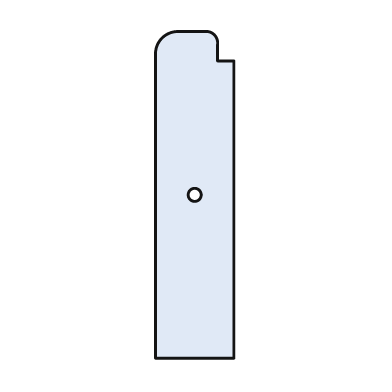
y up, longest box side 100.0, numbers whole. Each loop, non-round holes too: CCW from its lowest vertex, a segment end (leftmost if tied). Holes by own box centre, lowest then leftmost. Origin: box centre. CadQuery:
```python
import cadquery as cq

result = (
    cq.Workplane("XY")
    .moveTo(-12.0, -50.0)
    .lineTo(12.0, -50.0)
    .lineTo(12.0, 41.0)
    .lineTo(7.0, 41.0)
    .lineTo(7.0, 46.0)
    .threePointArc((6.0, 49.0), (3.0, 50.0))
    .lineTo(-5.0, 50.0)
    .threePointArc((-10.0, 48.0), (-12.0, 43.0))
    .close()
    .moveTo(0.0, 0.0)
    .circle(2.0)
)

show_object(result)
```